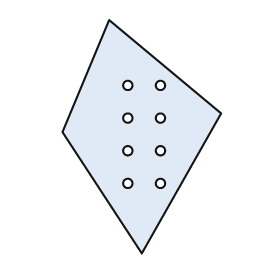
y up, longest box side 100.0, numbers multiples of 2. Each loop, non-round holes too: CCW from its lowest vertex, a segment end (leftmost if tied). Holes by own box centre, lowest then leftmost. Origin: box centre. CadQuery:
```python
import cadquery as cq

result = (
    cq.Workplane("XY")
    .moveTo(0.0, -50.0)
    .lineTo(34.0, 10.0)
    .lineTo(-14.0, 50.0)
    .lineTo(-34.0, 2.0)
    .close()
    .moveTo(-6.0, -20.0)
    .circle(2.0)
    .moveTo(8.0, -20.0)
    .circle(2.0)
    .moveTo(-6.0, -6.0)
    .circle(2.0)
    .moveTo(8.0, -6.0)
    .circle(2.0)
    .moveTo(-6.0, 8.0)
    .circle(2.0)
    .moveTo(8.0, 8.0)
    .circle(2.0)
    .moveTo(-6.0, 22.0)
    .circle(2.0)
    .moveTo(8.0, 22.0)
    .circle(2.0)
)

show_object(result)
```